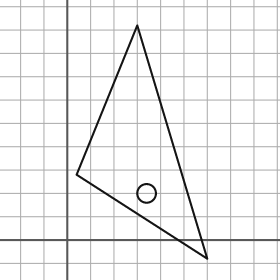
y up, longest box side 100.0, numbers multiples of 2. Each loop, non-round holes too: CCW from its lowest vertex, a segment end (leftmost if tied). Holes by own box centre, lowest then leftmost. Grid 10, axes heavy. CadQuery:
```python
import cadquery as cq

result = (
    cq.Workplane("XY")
    .moveTo(60.0, -8.0)
    .lineTo(30.0, 92.0)
    .lineTo(4.0, 28.0)
    .close()
    .moveTo(34.0, 20.0)
    .circle(4.0)
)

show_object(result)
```